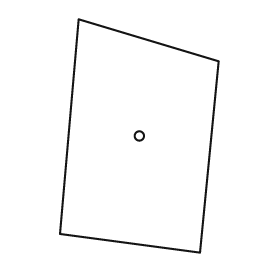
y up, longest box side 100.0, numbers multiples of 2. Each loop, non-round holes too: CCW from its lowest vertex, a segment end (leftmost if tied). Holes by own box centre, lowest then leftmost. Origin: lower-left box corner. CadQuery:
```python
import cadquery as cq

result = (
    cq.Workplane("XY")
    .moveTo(60.0, 0.0)
    .lineTo(68.0, 82.0)
    .lineTo(8.0, 100.0)
    .lineTo(0.0, 8.0)
    .close()
    .moveTo(34.0, 50.0)
    .circle(2.0)
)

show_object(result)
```